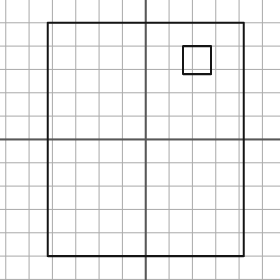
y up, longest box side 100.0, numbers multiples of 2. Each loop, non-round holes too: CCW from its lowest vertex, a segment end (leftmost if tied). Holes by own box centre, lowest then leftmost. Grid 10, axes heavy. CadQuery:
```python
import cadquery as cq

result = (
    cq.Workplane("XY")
    .moveTo(-42.0, -50.0)
    .lineTo(42.0, -50.0)
    .lineTo(42.0, 50.0)
    .lineTo(-42.0, 50.0)
    .close()
    .moveTo(16.0, 28.0)
    .lineTo(28.0, 28.0)
    .lineTo(28.0, 40.0)
    .lineTo(16.0, 40.0)
    .close()
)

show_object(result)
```